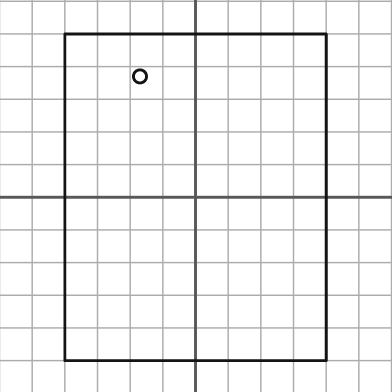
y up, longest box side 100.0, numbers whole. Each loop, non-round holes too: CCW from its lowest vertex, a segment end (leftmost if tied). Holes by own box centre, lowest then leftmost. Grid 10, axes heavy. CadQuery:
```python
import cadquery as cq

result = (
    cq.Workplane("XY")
    .moveTo(-40.0, -50.0)
    .lineTo(40.0, -50.0)
    .lineTo(40.0, 50.0)
    .lineTo(-40.0, 50.0)
    .close()
    .moveTo(-17.0, 37.0)
    .circle(2.0)
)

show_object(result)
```